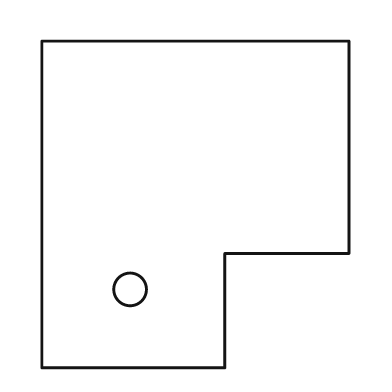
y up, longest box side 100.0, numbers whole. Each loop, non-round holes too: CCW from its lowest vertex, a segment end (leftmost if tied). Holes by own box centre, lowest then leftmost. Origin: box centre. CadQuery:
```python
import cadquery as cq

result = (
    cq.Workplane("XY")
    .moveTo(-47.0, -50.0)
    .lineTo(9.0, -50.0)
    .lineTo(9.0, -15.0)
    .lineTo(47.0, -15.0)
    .lineTo(47.0, 50.0)
    .lineTo(-47.0, 50.0)
    .close()
    .moveTo(-20.0, -26.0)
    .circle(5.0)
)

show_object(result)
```